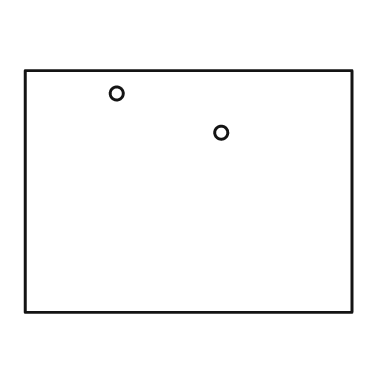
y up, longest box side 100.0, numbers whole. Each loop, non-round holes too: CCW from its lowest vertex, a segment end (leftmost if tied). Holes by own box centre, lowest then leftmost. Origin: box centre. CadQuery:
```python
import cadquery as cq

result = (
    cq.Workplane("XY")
    .moveTo(-50.0, -37.0)
    .lineTo(50.0, -37.0)
    .lineTo(50.0, 37.0)
    .lineTo(-50.0, 37.0)
    .close()
    .moveTo(10.0, 18.0)
    .circle(2.0)
    .moveTo(-22.0, 30.0)
    .circle(2.0)
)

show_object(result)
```